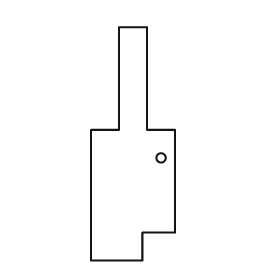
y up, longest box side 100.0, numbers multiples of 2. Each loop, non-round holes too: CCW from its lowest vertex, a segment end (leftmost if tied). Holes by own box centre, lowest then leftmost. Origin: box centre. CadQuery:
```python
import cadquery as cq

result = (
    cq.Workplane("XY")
    .moveTo(-18.0, -50.0)
    .lineTo(4.0, -50.0)
    .lineTo(4.0, -38.0)
    .lineTo(18.0, -38.0)
    .lineTo(18.0, 6.0)
    .lineTo(6.0, 6.0)
    .lineTo(6.0, 50.0)
    .lineTo(-6.0, 50.0)
    .lineTo(-6.0, 6.0)
    .lineTo(-18.0, 6.0)
    .close()
    .moveTo(12.0, -6.0)
    .circle(2.0)
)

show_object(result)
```